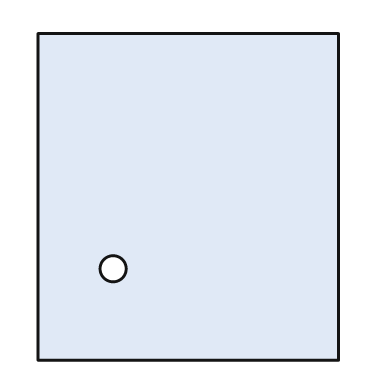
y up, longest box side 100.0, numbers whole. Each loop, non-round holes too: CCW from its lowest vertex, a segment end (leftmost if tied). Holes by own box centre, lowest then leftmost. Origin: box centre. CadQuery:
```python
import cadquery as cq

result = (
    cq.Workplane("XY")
    .moveTo(-46.0, -50.0)
    .lineTo(46.0, -50.0)
    .lineTo(46.0, 50.0)
    .lineTo(-46.0, 50.0)
    .close()
    .moveTo(-23.0, -22.0)
    .circle(4.0)
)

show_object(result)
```